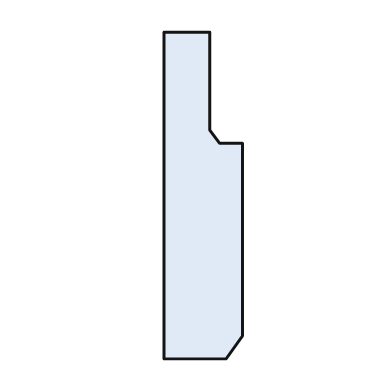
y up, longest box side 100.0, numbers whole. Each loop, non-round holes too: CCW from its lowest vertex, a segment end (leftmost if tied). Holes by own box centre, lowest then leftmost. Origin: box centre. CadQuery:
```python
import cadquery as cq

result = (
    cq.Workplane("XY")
    .moveTo(-12.0, -50.0)
    .lineTo(7.0, -50.0)
    .lineTo(12.0, -43.0)
    .lineTo(12.0, 16.0)
    .lineTo(5.0, 16.0)
    .lineTo(2.0, 20.0)
    .lineTo(2.0, 50.0)
    .lineTo(-12.0, 50.0)
    .close()
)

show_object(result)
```